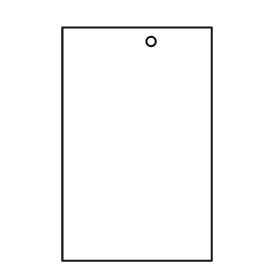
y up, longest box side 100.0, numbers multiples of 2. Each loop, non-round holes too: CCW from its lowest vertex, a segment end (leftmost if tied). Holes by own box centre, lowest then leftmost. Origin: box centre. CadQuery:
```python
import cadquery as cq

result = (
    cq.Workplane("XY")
    .moveTo(-32.0, -50.0)
    .lineTo(32.0, -50.0)
    .lineTo(32.0, 50.0)
    .lineTo(-32.0, 50.0)
    .close()
    .moveTo(6.0, 44.0)
    .circle(2.0)
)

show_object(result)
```